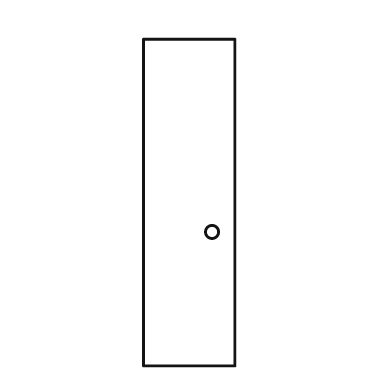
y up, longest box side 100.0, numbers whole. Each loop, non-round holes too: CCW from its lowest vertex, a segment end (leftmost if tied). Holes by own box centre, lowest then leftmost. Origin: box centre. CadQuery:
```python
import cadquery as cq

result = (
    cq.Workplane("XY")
    .moveTo(-14.0, -50.0)
    .lineTo(14.0, -50.0)
    .lineTo(14.0, 50.0)
    .lineTo(-14.0, 50.0)
    .close()
    .moveTo(7.0, -9.0)
    .circle(2.0)
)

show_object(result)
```